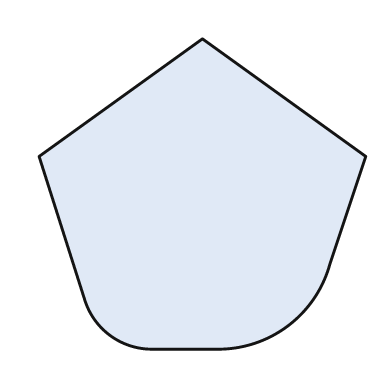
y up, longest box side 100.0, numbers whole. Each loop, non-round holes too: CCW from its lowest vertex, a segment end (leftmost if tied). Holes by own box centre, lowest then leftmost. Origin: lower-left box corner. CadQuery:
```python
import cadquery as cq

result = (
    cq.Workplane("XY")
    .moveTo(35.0, 0.0)
    .lineTo(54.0, 0.0)
    .threePointArc((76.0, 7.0), (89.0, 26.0))
    .lineTo(100.0, 59.0)
    .lineTo(50.0, 95.0)
    .lineTo(0.0, 59.0)
    .lineTo(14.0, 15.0)
    .threePointArc((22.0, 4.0), (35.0, 0.0))
    .close()
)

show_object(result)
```